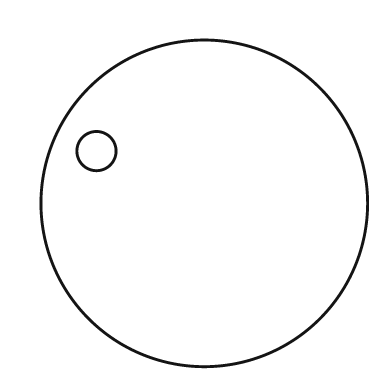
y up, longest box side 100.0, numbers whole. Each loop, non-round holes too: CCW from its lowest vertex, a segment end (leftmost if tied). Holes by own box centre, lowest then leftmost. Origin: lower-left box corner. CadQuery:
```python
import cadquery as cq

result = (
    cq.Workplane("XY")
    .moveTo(50.0, 50.0)
    .circle(50.0)
    .moveTo(17.0, 66.0)
    .circle(6.0)
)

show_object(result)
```